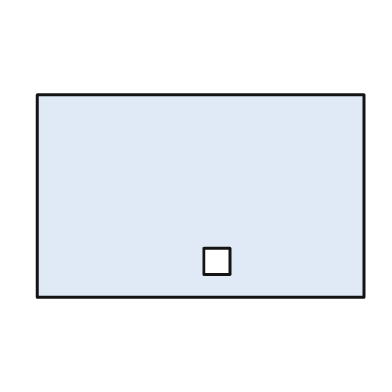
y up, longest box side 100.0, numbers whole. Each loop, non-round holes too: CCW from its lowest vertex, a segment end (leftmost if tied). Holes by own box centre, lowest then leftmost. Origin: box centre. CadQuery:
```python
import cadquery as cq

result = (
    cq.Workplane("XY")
    .moveTo(-50.0, -31.0)
    .lineTo(50.0, -31.0)
    .lineTo(50.0, 31.0)
    .lineTo(-50.0, 31.0)
    .close()
    .moveTo(1.0, -24.0)
    .lineTo(9.0, -24.0)
    .lineTo(9.0, -16.0)
    .lineTo(1.0, -16.0)
    .close()
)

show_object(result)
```